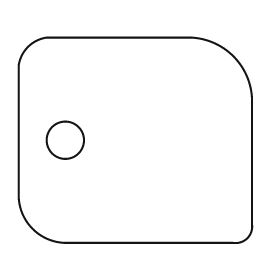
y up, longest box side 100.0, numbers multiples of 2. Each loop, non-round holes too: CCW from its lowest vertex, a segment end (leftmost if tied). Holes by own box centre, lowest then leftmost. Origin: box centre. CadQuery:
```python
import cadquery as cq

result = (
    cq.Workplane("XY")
    .moveTo(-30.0, -44.0)
    .lineTo(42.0, -44.0)
    .threePointArc((48.0, -42.0), (50.0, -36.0))
    .lineTo(50.0, 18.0)
    .threePointArc((42.0, 36.0), (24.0, 44.0))
    .lineTo(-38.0, 44.0)
    .threePointArc((-46.0, 40.0), (-50.0, 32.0))
    .lineTo(-50.0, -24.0)
    .threePointArc((-44.0, -38.0), (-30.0, -44.0))
    .close()
    .moveTo(-30.0, 0.0)
    .circle(8.0)
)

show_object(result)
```